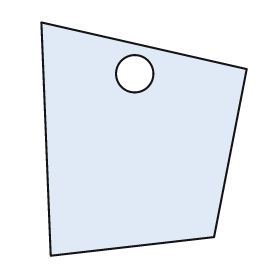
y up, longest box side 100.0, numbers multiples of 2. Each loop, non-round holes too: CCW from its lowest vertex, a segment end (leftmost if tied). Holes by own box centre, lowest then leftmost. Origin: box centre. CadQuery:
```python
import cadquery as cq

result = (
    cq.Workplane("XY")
    .moveTo(-40.0, -50.0)
    .lineTo(30.0, -42.0)
    .lineTo(44.0, 30.0)
    .lineTo(-44.0, 50.0)
    .close()
    .moveTo(-4.0, 28.0)
    .circle(8.0)
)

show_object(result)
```